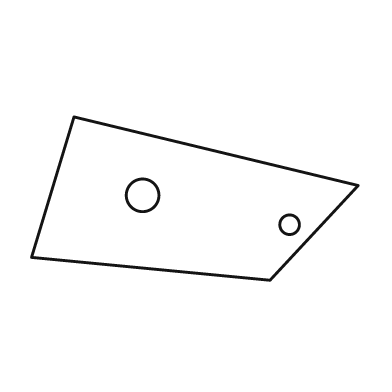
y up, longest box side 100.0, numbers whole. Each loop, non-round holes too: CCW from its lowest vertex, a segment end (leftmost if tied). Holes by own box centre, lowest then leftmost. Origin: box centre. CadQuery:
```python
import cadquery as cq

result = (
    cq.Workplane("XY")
    .moveTo(23.0, -25.0)
    .lineTo(50.0, 4.0)
    .lineTo(-37.0, 25.0)
    .lineTo(-50.0, -18.0)
    .close()
    .moveTo(29.0, -8.0)
    .circle(3.0)
    .moveTo(-16.0, 1.0)
    .circle(5.0)
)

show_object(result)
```